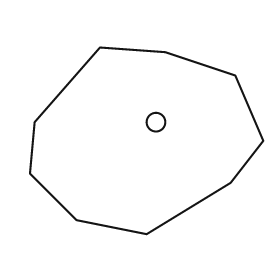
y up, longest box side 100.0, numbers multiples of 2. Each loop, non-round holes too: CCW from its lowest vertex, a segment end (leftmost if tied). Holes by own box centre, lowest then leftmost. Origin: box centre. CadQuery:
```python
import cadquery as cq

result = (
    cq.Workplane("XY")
    .moveTo(0.0, -40.0)
    .lineTo(36.0, -18.0)
    .lineTo(50.0, 0.0)
    .lineTo(38.0, 28.0)
    .lineTo(8.0, 38.0)
    .lineTo(-20.0, 40.0)
    .lineTo(-48.0, 8.0)
    .lineTo(-50.0, -14.0)
    .lineTo(-30.0, -34.0)
    .close()
    .moveTo(4.0, 8.0)
    .circle(4.0)
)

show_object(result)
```